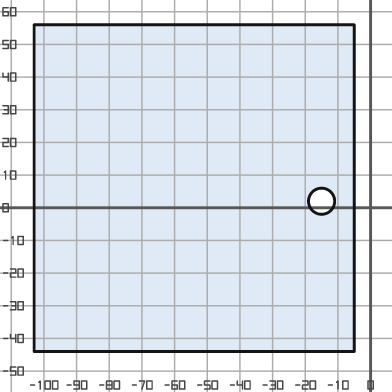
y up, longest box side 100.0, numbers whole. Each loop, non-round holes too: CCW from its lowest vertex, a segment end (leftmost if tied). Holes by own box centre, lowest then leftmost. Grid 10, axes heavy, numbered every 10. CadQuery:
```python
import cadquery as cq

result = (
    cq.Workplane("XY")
    .moveTo(-103.0, -44.0)
    .lineTo(-5.0, -44.0)
    .lineTo(-5.0, 56.0)
    .lineTo(-103.0, 56.0)
    .close()
    .moveTo(-15.0, 2.0)
    .circle(4.0)
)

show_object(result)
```